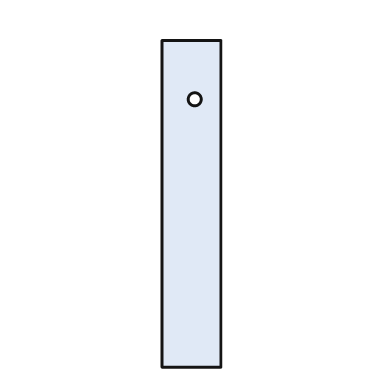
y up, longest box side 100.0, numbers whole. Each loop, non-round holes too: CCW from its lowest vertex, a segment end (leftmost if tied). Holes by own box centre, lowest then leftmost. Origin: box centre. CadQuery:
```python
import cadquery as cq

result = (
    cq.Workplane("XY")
    .moveTo(-9.0, -50.0)
    .lineTo(9.0, -50.0)
    .lineTo(9.0, 50.0)
    .lineTo(-9.0, 50.0)
    .close()
    .moveTo(1.0, 32.0)
    .circle(2.0)
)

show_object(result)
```